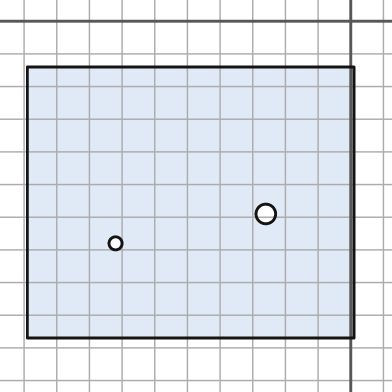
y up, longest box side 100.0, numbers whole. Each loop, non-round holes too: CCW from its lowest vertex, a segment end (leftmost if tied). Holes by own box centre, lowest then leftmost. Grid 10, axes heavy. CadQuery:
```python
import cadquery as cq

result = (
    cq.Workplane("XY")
    .moveTo(-99.0, -97.0)
    .lineTo(1.0, -97.0)
    .lineTo(1.0, -14.0)
    .lineTo(-99.0, -14.0)
    .close()
    .moveTo(-72.0, -68.0)
    .circle(2.0)
    .moveTo(-26.0, -59.0)
    .circle(3.0)
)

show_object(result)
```